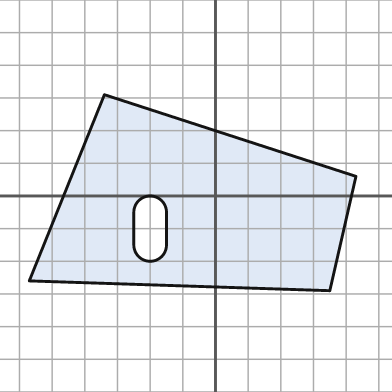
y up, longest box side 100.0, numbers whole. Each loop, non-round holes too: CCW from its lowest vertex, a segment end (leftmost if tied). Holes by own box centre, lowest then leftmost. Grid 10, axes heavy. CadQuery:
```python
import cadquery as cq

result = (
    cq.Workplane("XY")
    .moveTo(35.0, -29.0)
    .lineTo(43.0, 6.0)
    .lineTo(-34.0, 31.0)
    .lineTo(-57.0, -26.0)
    .close()
    .moveTo(-25.0, -15.0)
    .threePointArc((-20.0, -20.0), (-15.0, -15.0))
    .lineTo(-15.0, -5.0)
    .threePointArc((-20.0, 0.0), (-25.0, -5.0))
    .close()
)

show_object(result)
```